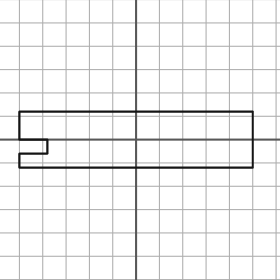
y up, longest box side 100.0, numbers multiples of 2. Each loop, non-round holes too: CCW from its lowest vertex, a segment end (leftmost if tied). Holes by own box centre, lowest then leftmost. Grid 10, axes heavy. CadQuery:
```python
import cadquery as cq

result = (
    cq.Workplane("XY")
    .moveTo(-50.0, -12.0)
    .lineTo(50.0, -12.0)
    .lineTo(50.0, 12.0)
    .lineTo(-50.0, 12.0)
    .lineTo(-50.0, 0.0)
    .lineTo(-38.0, 0.0)
    .lineTo(-38.0, -6.0)
    .lineTo(-50.0, -6.0)
    .close()
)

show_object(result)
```